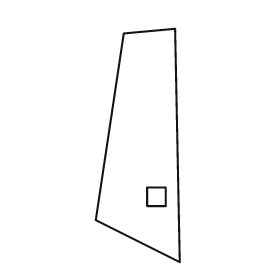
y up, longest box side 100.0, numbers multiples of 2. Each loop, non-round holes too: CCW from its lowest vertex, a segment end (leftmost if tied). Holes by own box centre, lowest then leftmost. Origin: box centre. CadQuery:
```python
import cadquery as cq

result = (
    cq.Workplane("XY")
    .moveTo(18.0, -50.0)
    .lineTo(16.0, 50.0)
    .lineTo(-6.0, 48.0)
    .lineTo(-18.0, -32.0)
    .close()
    .moveTo(4.0, -26.0)
    .lineTo(12.0, -26.0)
    .lineTo(12.0, -18.0)
    .lineTo(4.0, -18.0)
    .close()
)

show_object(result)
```